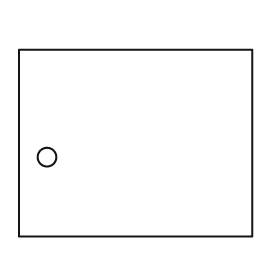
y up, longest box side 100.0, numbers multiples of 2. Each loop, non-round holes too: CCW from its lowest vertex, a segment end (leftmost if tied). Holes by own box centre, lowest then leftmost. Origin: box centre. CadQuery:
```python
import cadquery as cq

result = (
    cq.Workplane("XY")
    .moveTo(-50.0, -40.0)
    .lineTo(50.0, -40.0)
    .lineTo(50.0, 40.0)
    .lineTo(-50.0, 40.0)
    .close()
    .moveTo(-38.0, -6.0)
    .circle(4.0)
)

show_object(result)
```